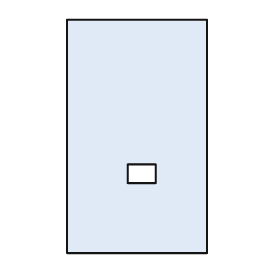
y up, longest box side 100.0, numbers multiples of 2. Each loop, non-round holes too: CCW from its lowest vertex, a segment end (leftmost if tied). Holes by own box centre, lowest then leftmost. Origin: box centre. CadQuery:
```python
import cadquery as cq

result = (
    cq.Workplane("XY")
    .moveTo(-30.0, -50.0)
    .lineTo(30.0, -50.0)
    .lineTo(30.0, 50.0)
    .lineTo(-30.0, 50.0)
    .close()
    .moveTo(-4.0, -20.0)
    .lineTo(8.0, -20.0)
    .lineTo(8.0, -12.0)
    .lineTo(-4.0, -12.0)
    .close()
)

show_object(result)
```